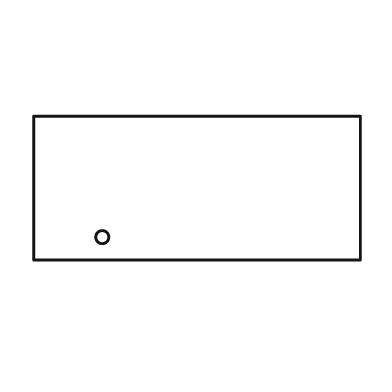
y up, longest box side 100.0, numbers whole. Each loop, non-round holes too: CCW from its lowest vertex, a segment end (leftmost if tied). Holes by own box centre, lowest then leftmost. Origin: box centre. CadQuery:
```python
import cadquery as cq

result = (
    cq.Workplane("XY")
    .moveTo(-50.0, -22.0)
    .lineTo(50.0, -22.0)
    .lineTo(50.0, 22.0)
    .lineTo(-50.0, 22.0)
    .close()
    .moveTo(-29.0, -15.0)
    .circle(2.0)
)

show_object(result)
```